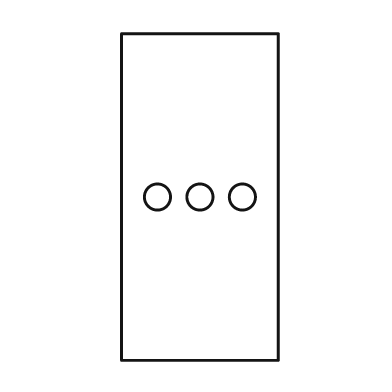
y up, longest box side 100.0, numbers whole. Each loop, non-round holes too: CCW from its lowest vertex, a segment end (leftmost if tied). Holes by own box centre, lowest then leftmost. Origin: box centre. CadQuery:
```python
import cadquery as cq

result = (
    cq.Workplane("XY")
    .moveTo(-24.0, -50.0)
    .lineTo(24.0, -50.0)
    .lineTo(24.0, 50.0)
    .lineTo(-24.0, 50.0)
    .close()
    .moveTo(-13.0, 0.0)
    .circle(4.0)
    .moveTo(0.0, 0.0)
    .circle(4.0)
    .moveTo(13.0, 0.0)
    .circle(4.0)
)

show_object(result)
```